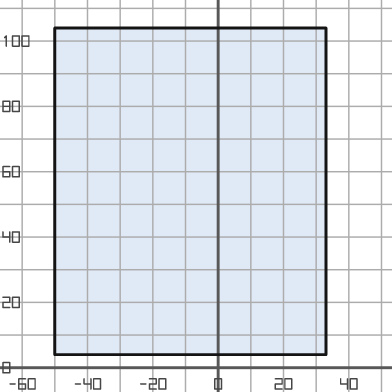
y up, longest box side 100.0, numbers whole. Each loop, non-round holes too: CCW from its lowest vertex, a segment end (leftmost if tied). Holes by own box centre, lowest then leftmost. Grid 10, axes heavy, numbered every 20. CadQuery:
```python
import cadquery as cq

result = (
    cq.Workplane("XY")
    .moveTo(-50.0, 4.0)
    .lineTo(33.0, 4.0)
    .lineTo(33.0, 104.0)
    .lineTo(-50.0, 104.0)
    .close()
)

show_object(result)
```